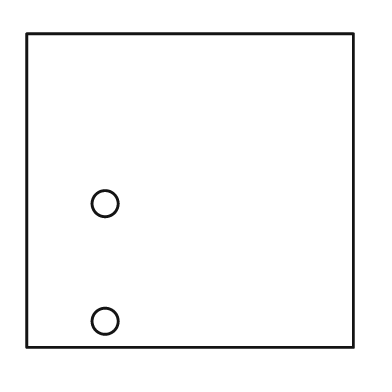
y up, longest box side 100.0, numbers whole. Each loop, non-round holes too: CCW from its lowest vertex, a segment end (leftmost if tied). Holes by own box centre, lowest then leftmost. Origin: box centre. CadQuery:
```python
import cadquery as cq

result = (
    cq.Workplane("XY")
    .moveTo(-50.0, -48.0)
    .lineTo(50.0, -48.0)
    .lineTo(50.0, 48.0)
    .lineTo(-50.0, 48.0)
    .close()
    .moveTo(-26.0, -40.0)
    .circle(4.0)
    .moveTo(-26.0, -4.0)
    .circle(4.0)
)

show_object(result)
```